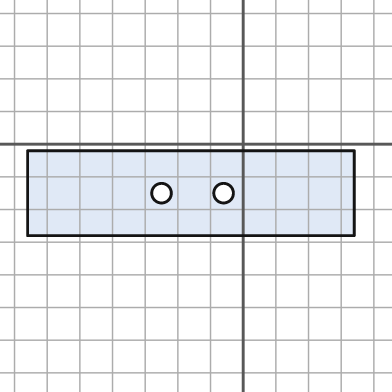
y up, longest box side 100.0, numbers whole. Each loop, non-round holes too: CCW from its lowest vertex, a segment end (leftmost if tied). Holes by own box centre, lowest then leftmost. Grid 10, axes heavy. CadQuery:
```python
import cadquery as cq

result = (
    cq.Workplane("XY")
    .moveTo(-66.0, -28.0)
    .lineTo(34.0, -28.0)
    .lineTo(34.0, -2.0)
    .lineTo(-66.0, -2.0)
    .close()
    .moveTo(-25.0, -15.0)
    .circle(3.0)
    .moveTo(-6.0, -15.0)
    .circle(3.0)
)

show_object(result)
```